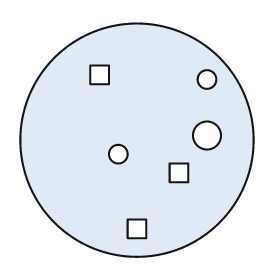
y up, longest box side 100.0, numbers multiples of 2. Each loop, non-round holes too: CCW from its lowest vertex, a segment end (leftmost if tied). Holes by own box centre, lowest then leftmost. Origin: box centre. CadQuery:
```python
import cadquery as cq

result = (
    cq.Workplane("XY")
    .moveTo(0.0, 0.0)
    .circle(50.0)
    .moveTo(-4.0, -42.0)
    .lineTo(4.0, -42.0)
    .lineTo(4.0, -34.0)
    .lineTo(-4.0, -34.0)
    .close()
    .moveTo(14.0, -18.0)
    .lineTo(22.0, -18.0)
    .lineTo(22.0, -10.0)
    .lineTo(14.0, -10.0)
    .close()
    .moveTo(-8.0, -6.0)
    .circle(4.0)
    .moveTo(30.0, 2.0)
    .circle(6.0)
    .moveTo(30.0, 26.0)
    .circle(4.0)
    .moveTo(-20.0, 24.0)
    .lineTo(-12.0, 24.0)
    .lineTo(-12.0, 32.0)
    .lineTo(-20.0, 32.0)
    .close()
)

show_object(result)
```